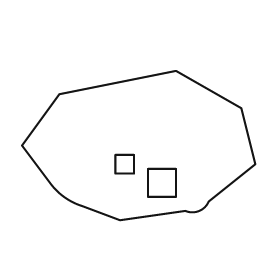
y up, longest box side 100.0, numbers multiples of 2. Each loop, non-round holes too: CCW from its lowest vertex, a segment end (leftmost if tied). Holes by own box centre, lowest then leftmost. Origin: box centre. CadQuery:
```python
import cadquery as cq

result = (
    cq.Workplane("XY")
    .moveTo(-8.0, -32.0)
    .lineTo(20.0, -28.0)
    .threePointArc((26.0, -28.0), (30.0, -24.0))
    .lineTo(50.0, -8.0)
    .lineTo(44.0, 16.0)
    .lineTo(16.0, 32.0)
    .lineTo(-34.0, 22.0)
    .lineTo(-50.0, 0.0)
    .lineTo(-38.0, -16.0)
    .threePointArc((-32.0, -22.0), (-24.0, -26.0))
    .close()
    .moveTo(4.0, -22.0)
    .lineTo(16.0, -22.0)
    .lineTo(16.0, -10.0)
    .lineTo(4.0, -10.0)
    .close()
    .moveTo(-10.0, -12.0)
    .lineTo(-2.0, -12.0)
    .lineTo(-2.0, -4.0)
    .lineTo(-10.0, -4.0)
    .close()
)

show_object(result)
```